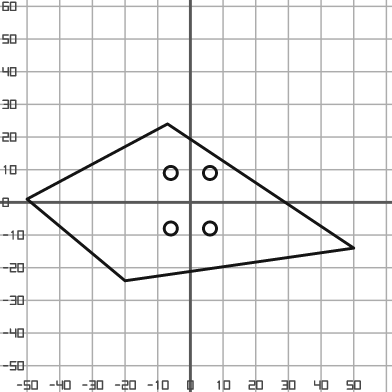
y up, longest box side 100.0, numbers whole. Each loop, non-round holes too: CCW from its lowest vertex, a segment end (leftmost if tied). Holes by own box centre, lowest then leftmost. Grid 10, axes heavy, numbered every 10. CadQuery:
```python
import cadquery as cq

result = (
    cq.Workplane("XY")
    .moveTo(-20.0, -24.0)
    .lineTo(50.0, -14.0)
    .lineTo(-7.0, 24.0)
    .lineTo(-50.0, 1.0)
    .close()
    .moveTo(-6.0, -8.0)
    .circle(2.0)
    .moveTo(6.0, -8.0)
    .circle(2.0)
    .moveTo(-6.0, 9.0)
    .circle(2.0)
    .moveTo(6.0, 9.0)
    .circle(2.0)
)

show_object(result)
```